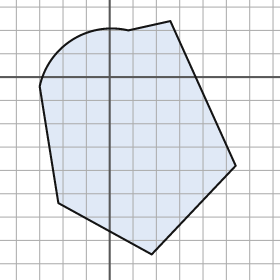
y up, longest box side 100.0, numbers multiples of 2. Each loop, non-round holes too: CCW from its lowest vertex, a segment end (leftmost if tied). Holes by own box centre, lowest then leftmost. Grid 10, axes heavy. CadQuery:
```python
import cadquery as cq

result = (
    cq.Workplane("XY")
    .moveTo(18.0, -76.0)
    .lineTo(54.0, -38.0)
    .lineTo(26.0, 24.0)
    .lineTo(8.0, 20.0)
    .threePointArc((-16.0, 16.0), (-30.0, -4.0))
    .lineTo(-22.0, -54.0)
    .close()
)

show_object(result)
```